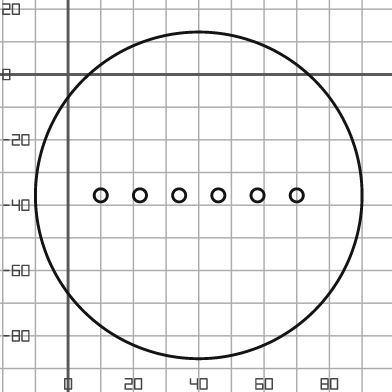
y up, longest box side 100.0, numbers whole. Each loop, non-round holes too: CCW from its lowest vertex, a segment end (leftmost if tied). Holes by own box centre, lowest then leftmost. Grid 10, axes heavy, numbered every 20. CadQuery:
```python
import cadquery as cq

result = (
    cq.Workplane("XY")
    .moveTo(40.0, -37.0)
    .circle(50.0)
    .moveTo(10.0, -37.0)
    .circle(2.0)
    .moveTo(22.0, -37.0)
    .circle(2.0)
    .moveTo(34.0, -37.0)
    .circle(2.0)
    .moveTo(46.0, -37.0)
    .circle(2.0)
    .moveTo(58.0, -37.0)
    .circle(2.0)
    .moveTo(70.0, -37.0)
    .circle(2.0)
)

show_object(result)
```